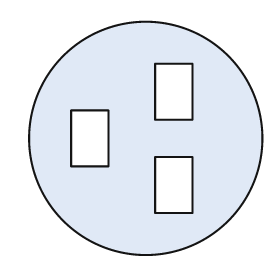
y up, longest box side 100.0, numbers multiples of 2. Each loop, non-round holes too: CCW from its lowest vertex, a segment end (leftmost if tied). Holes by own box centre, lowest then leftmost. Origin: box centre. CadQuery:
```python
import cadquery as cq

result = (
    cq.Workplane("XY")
    .moveTo(0.0, 0.0)
    .circle(50.0)
    .moveTo(4.0, -32.0)
    .lineTo(20.0, -32.0)
    .lineTo(20.0, -8.0)
    .lineTo(4.0, -8.0)
    .close()
    .moveTo(-32.0, -12.0)
    .lineTo(-16.0, -12.0)
    .lineTo(-16.0, 12.0)
    .lineTo(-32.0, 12.0)
    .close()
    .moveTo(4.0, 8.0)
    .lineTo(20.0, 8.0)
    .lineTo(20.0, 32.0)
    .lineTo(4.0, 32.0)
    .close()
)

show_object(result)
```